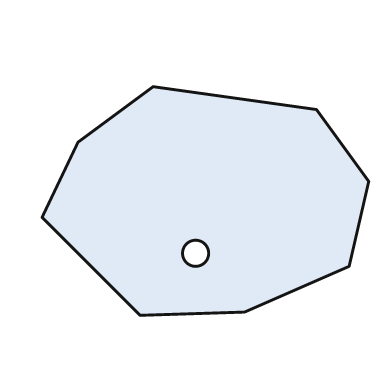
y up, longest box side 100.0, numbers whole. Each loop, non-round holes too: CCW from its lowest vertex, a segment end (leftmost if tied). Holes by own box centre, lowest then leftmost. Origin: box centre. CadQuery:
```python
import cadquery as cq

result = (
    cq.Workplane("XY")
    .moveTo(-20.0, -35.0)
    .lineTo(12.0, -34.0)
    .lineTo(44.0, -20.0)
    .lineTo(50.0, 6.0)
    .lineTo(34.0, 28.0)
    .lineTo(-16.0, 35.0)
    .lineTo(-39.0, 18.0)
    .lineTo(-50.0, -5.0)
    .close()
    .moveTo(-3.0, -16.0)
    .circle(4.0)
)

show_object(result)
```